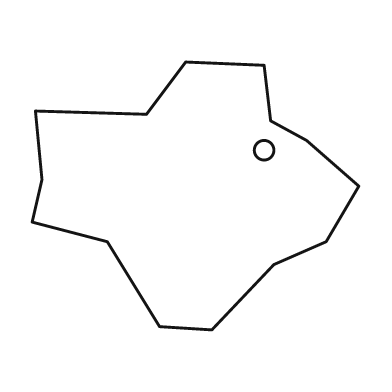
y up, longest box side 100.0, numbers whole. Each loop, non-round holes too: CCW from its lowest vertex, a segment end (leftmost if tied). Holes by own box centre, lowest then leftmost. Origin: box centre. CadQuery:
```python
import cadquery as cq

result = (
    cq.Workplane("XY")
    .moveTo(5.0, -41.0)
    .lineTo(24.0, -21.0)
    .lineTo(40.0, -14.0)
    .lineTo(50.0, 3.0)
    .lineTo(34.0, 17.0)
    .lineTo(23.0, 23.0)
    .lineTo(21.0, 40.0)
    .lineTo(-3.0, 41.0)
    .lineTo(-15.0, 25.0)
    .lineTo(-49.0, 26.0)
    .lineTo(-47.0, 5.0)
    .lineTo(-50.0, -8.0)
    .lineTo(-27.0, -14.0)
    .lineTo(-11.0, -40.0)
    .close()
    .moveTo(21.0, 14.0)
    .circle(3.0)
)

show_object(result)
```